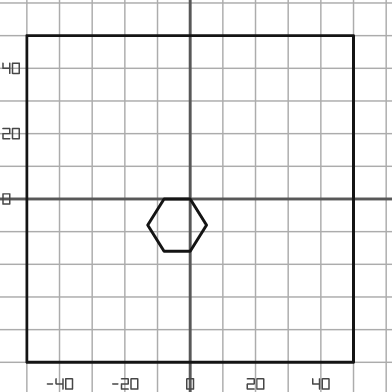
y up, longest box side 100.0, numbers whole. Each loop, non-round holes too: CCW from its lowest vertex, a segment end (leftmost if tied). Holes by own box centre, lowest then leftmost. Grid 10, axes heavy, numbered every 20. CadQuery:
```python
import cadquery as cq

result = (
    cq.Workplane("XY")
    .moveTo(-50.0, -50.0)
    .lineTo(50.0, -50.0)
    .lineTo(50.0, 50.0)
    .lineTo(-50.0, 50.0)
    .close()
    .moveTo(-8.0, -16.0)
    .lineTo(0.0, -16.0)
    .lineTo(5.0, -8.0)
    .lineTo(0.0, 0.0)
    .lineTo(-8.0, 0.0)
    .lineTo(-13.0, -8.0)
    .close()
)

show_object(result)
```